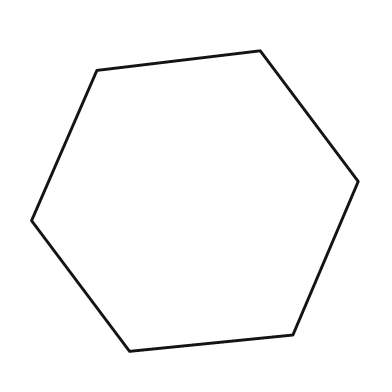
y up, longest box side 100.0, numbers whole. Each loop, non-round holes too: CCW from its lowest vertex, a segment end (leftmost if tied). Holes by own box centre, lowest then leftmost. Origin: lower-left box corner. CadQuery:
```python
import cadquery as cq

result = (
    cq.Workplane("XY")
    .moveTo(30.0, 0.0)
    .lineTo(80.0, 5.0)
    .lineTo(100.0, 52.0)
    .lineTo(70.0, 92.0)
    .lineTo(20.0, 86.0)
    .lineTo(0.0, 40.0)
    .close()
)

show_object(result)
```